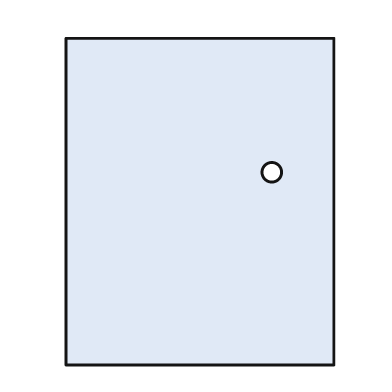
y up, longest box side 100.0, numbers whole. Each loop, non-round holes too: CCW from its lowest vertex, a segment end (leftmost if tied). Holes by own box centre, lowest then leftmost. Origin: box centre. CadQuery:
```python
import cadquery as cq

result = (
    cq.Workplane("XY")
    .moveTo(-41.0, -50.0)
    .lineTo(41.0, -50.0)
    .lineTo(41.0, 50.0)
    .lineTo(-41.0, 50.0)
    .close()
    .moveTo(22.0, 9.0)
    .circle(3.0)
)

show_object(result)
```